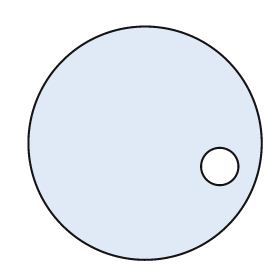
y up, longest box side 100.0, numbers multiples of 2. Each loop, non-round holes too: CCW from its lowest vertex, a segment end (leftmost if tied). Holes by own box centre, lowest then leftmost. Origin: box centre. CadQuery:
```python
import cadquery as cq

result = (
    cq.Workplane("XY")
    .moveTo(0.0, 0.0)
    .circle(50.0)
    .moveTo(32.0, -10.0)
    .circle(8.0)
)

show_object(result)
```